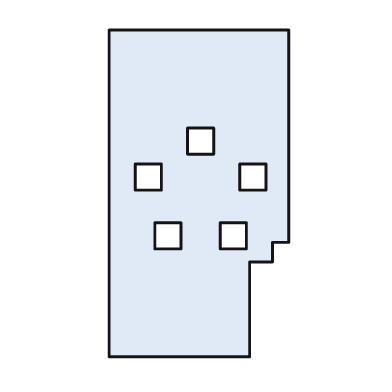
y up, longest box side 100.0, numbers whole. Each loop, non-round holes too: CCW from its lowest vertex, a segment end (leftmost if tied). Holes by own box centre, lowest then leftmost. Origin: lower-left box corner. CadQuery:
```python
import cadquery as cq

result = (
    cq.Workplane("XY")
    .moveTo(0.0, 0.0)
    .lineTo(43.0, 0.0)
    .lineTo(43.0, 29.0)
    .lineTo(50.0, 29.0)
    .lineTo(50.0, 35.0)
    .lineTo(55.0, 35.0)
    .lineTo(55.0, 100.0)
    .lineTo(0.0, 100.0)
    .close()
    .moveTo(14.0, 33.0)
    .lineTo(22.0, 33.0)
    .lineTo(22.0, 41.0)
    .lineTo(14.0, 41.0)
    .close()
    .moveTo(34.0, 33.0)
    .lineTo(42.0, 33.0)
    .lineTo(42.0, 41.0)
    .lineTo(34.0, 41.0)
    .close()
    .moveTo(8.0, 51.0)
    .lineTo(16.0, 51.0)
    .lineTo(16.0, 59.0)
    .lineTo(8.0, 59.0)
    .close()
    .moveTo(40.0, 51.0)
    .lineTo(48.0, 51.0)
    .lineTo(48.0, 59.0)
    .lineTo(40.0, 59.0)
    .close()
    .moveTo(24.0, 62.0)
    .lineTo(32.0, 62.0)
    .lineTo(32.0, 70.0)
    .lineTo(24.0, 70.0)
    .close()
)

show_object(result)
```